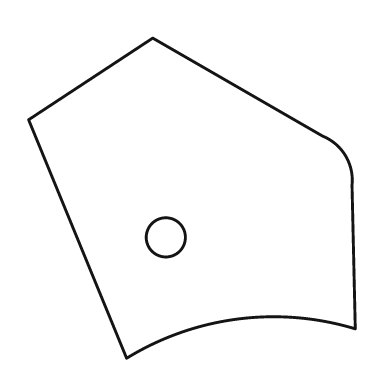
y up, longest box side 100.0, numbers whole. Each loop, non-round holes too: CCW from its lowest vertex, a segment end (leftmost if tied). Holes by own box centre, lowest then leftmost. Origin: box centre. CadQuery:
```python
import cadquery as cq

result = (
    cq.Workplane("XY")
    .moveTo(-20.0, -49.0)
    .threePointArc((14.0, -37.0), (50.0, -40.0))
    .lineTo(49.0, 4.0)
    .threePointArc((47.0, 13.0), (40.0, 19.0))
    .lineTo(-12.0, 49.0)
    .lineTo(-50.0, 24.0)
    .close()
    .moveTo(-8.0, -12.0)
    .circle(6.0)
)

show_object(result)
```